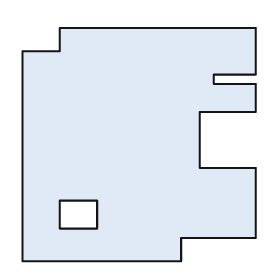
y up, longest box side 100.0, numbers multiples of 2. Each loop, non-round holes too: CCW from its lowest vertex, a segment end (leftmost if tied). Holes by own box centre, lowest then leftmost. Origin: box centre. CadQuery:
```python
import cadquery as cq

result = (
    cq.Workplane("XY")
    .moveTo(-50.0, -50.0)
    .lineTo(18.0, -50.0)
    .lineTo(18.0, -40.0)
    .lineTo(50.0, -40.0)
    .lineTo(50.0, -10.0)
    .lineTo(26.0, -10.0)
    .lineTo(26.0, 14.0)
    .lineTo(50.0, 14.0)
    .lineTo(50.0, 26.0)
    .lineTo(32.0, 26.0)
    .lineTo(32.0, 30.0)
    .lineTo(50.0, 30.0)
    .lineTo(50.0, 50.0)
    .lineTo(-34.0, 50.0)
    .lineTo(-34.0, 40.0)
    .lineTo(-50.0, 40.0)
    .close()
    .moveTo(-34.0, -36.0)
    .lineTo(-18.0, -36.0)
    .lineTo(-18.0, -24.0)
    .lineTo(-34.0, -24.0)
    .close()
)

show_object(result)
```